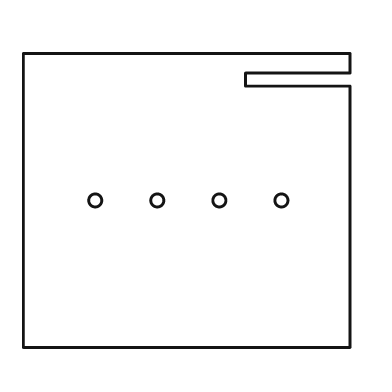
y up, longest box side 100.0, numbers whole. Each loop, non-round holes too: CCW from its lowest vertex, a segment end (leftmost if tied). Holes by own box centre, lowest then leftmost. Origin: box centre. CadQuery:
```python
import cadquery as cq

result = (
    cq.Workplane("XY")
    .moveTo(-50.0, -45.0)
    .lineTo(50.0, -45.0)
    .lineTo(50.0, 35.0)
    .lineTo(18.0, 35.0)
    .lineTo(18.0, 39.0)
    .lineTo(50.0, 39.0)
    .lineTo(50.0, 45.0)
    .lineTo(-50.0, 45.0)
    .close()
    .moveTo(-28.0, 0.0)
    .circle(2.0)
    .moveTo(-9.0, 0.0)
    .circle(2.0)
    .moveTo(10.0, 0.0)
    .circle(2.0)
    .moveTo(29.0, 0.0)
    .circle(2.0)
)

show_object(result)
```